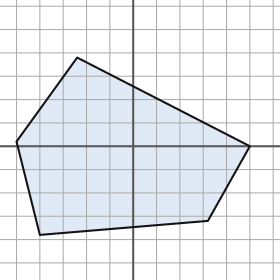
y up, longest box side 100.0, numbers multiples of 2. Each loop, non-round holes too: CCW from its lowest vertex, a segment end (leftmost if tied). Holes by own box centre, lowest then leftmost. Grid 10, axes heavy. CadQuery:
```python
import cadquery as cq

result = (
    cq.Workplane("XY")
    .moveTo(-40.0, -38.0)
    .lineTo(32.0, -32.0)
    .lineTo(50.0, 0.0)
    .lineTo(-24.0, 38.0)
    .lineTo(-50.0, 2.0)
    .close()
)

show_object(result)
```